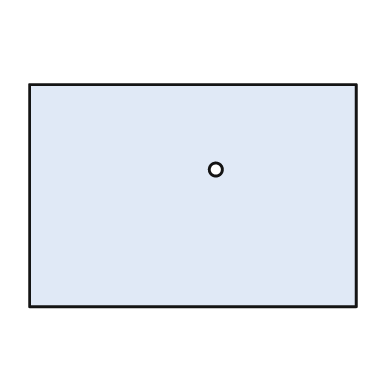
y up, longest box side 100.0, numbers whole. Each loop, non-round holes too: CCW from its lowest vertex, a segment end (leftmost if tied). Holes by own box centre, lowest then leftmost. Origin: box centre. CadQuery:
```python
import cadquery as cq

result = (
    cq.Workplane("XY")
    .moveTo(-50.0, -34.0)
    .lineTo(50.0, -34.0)
    .lineTo(50.0, 34.0)
    .lineTo(-50.0, 34.0)
    .close()
    .moveTo(7.0, 8.0)
    .circle(2.0)
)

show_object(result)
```